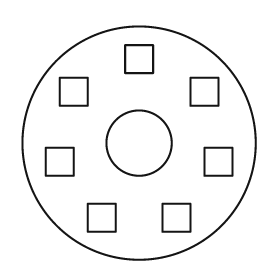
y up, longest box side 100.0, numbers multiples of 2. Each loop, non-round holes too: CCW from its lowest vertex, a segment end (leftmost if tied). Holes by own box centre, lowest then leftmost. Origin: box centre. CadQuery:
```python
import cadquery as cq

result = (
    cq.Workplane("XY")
    .moveTo(0.0, 0.0)
    .circle(50.0)
    .moveTo(-22.0, -38.0)
    .lineTo(-10.0, -38.0)
    .lineTo(-10.0, -26.0)
    .lineTo(-22.0, -26.0)
    .close()
    .moveTo(10.0, -38.0)
    .lineTo(22.0, -38.0)
    .lineTo(22.0, -26.0)
    .lineTo(10.0, -26.0)
    .close()
    .moveTo(-40.0, -14.0)
    .lineTo(-28.0, -14.0)
    .lineTo(-28.0, -2.0)
    .lineTo(-40.0, -2.0)
    .close()
    .moveTo(28.0, -14.0)
    .lineTo(40.0, -14.0)
    .lineTo(40.0, -2.0)
    .lineTo(28.0, -2.0)
    .close()
    .moveTo(0.0, 0.0)
    .circle(14.0)
    .moveTo(-34.0, 16.0)
    .lineTo(-22.0, 16.0)
    .lineTo(-22.0, 28.0)
    .lineTo(-34.0, 28.0)
    .close()
    .moveTo(22.0, 16.0)
    .lineTo(34.0, 16.0)
    .lineTo(34.0, 28.0)
    .lineTo(22.0, 28.0)
    .close()
    .moveTo(-6.0, 30.0)
    .lineTo(6.0, 30.0)
    .lineTo(6.0, 42.0)
    .lineTo(-6.0, 42.0)
    .close()
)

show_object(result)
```